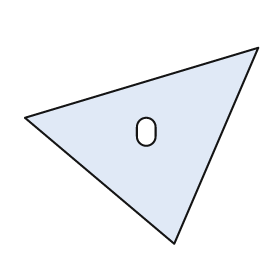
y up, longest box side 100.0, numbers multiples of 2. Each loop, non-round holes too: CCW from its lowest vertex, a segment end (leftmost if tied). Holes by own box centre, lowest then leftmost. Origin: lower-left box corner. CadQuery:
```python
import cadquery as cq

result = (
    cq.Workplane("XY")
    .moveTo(64.0, 0.0)
    .lineTo(100.0, 84.0)
    .lineTo(0.0, 54.0)
    .close()
    .moveTo(48.0, 46.0)
    .threePointArc((52.0, 42.0), (56.0, 46.0))
    .lineTo(56.0, 50.0)
    .threePointArc((52.0, 54.0), (48.0, 50.0))
    .close()
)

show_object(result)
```